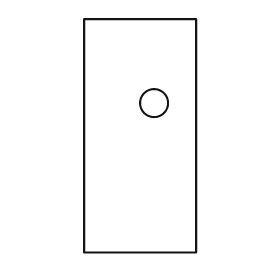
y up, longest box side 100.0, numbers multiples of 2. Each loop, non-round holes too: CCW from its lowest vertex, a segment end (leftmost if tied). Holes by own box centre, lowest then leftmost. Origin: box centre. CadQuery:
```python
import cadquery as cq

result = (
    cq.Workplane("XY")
    .moveTo(-24.0, -50.0)
    .lineTo(24.0, -50.0)
    .lineTo(24.0, 50.0)
    .lineTo(-24.0, 50.0)
    .close()
    .moveTo(6.0, 14.0)
    .circle(6.0)
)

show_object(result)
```